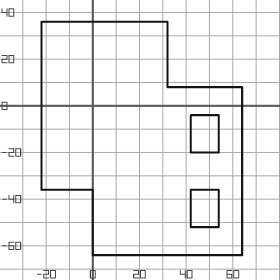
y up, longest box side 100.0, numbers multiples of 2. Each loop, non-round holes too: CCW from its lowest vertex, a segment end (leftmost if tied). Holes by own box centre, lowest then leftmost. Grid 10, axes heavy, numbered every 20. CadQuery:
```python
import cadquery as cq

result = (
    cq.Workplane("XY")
    .moveTo(0.0, -64.0)
    .lineTo(64.0, -64.0)
    .lineTo(64.0, 8.0)
    .lineTo(32.0, 8.0)
    .lineTo(32.0, 36.0)
    .lineTo(-22.0, 36.0)
    .lineTo(-22.0, -36.0)
    .lineTo(0.0, -36.0)
    .close()
    .moveTo(42.0, -52.0)
    .lineTo(54.0, -52.0)
    .lineTo(54.0, -36.0)
    .lineTo(42.0, -36.0)
    .close()
    .moveTo(42.0, -20.0)
    .lineTo(54.0, -20.0)
    .lineTo(54.0, -4.0)
    .lineTo(42.0, -4.0)
    .close()
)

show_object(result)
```